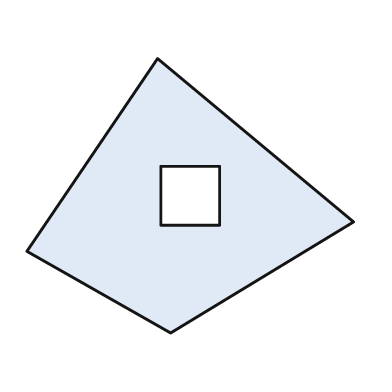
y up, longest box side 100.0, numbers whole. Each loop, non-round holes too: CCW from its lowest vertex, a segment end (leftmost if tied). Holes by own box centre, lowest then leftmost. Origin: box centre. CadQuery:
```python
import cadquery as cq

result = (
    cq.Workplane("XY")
    .moveTo(-6.0, -42.0)
    .lineTo(50.0, -8.0)
    .lineTo(-10.0, 42.0)
    .lineTo(-50.0, -17.0)
    .close()
    .moveTo(-9.0, -9.0)
    .lineTo(9.0, -9.0)
    .lineTo(9.0, 9.0)
    .lineTo(-9.0, 9.0)
    .close()
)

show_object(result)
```